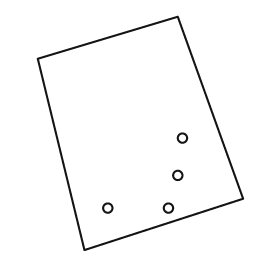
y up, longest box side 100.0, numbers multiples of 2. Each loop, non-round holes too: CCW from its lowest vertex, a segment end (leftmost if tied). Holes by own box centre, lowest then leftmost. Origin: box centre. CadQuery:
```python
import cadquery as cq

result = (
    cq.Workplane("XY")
    .moveTo(-24.0, -50.0)
    .lineTo(44.0, -28.0)
    .lineTo(16.0, 50.0)
    .lineTo(-44.0, 32.0)
    .close()
    .moveTo(-14.0, -32.0)
    .circle(2.0)
    .moveTo(12.0, -32.0)
    .circle(2.0)
    .moveTo(16.0, -18.0)
    .circle(2.0)
    .moveTo(18.0, -2.0)
    .circle(2.0)
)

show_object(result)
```